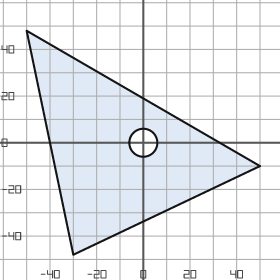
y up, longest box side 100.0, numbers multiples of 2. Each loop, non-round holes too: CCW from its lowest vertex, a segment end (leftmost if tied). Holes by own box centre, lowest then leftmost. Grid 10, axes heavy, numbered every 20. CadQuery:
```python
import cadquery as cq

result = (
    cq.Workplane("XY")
    .moveTo(-30.0, -48.0)
    .lineTo(50.0, -10.0)
    .lineTo(-50.0, 48.0)
    .close()
    .moveTo(0.0, 0.0)
    .circle(6.0)
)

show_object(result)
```